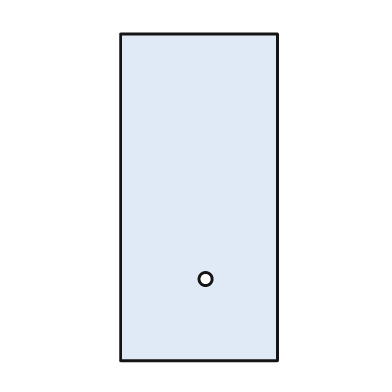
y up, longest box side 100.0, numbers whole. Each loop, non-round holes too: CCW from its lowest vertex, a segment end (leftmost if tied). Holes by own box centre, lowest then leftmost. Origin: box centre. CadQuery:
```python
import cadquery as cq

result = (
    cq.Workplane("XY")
    .moveTo(-24.0, -50.0)
    .lineTo(24.0, -50.0)
    .lineTo(24.0, 50.0)
    .lineTo(-24.0, 50.0)
    .close()
    .moveTo(2.0, -25.0)
    .circle(2.0)
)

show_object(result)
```